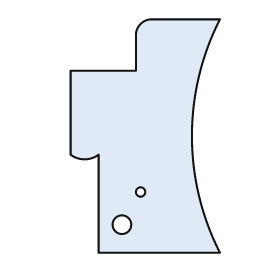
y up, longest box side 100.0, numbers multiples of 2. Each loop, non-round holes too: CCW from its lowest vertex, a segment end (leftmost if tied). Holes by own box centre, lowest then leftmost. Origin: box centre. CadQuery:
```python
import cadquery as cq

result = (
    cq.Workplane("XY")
    .moveTo(-20.0, -50.0)
    .lineTo(32.0, -50.0)
    .threePointArc((20.0, 0.0), (32.0, 50.0))
    .lineTo(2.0, 50.0)
    .threePointArc((-2.0, 48.0), (-4.0, 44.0))
    .lineTo(-4.0, 28.0)
    .lineTo(-32.0, 28.0)
    .lineTo(-32.0, -8.0)
    .threePointArc((-26.0, -10.0), (-20.0, -8.0))
    .close()
    .moveTo(-10.0, -38.0)
    .circle(4.0)
    .moveTo(-2.0, -24.0)
    .circle(2.0)
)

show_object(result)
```